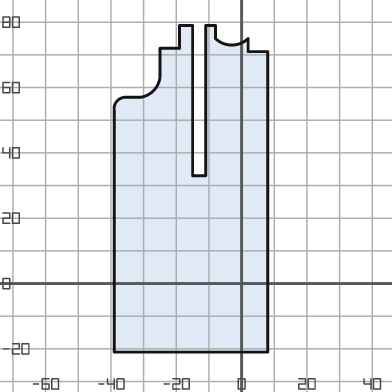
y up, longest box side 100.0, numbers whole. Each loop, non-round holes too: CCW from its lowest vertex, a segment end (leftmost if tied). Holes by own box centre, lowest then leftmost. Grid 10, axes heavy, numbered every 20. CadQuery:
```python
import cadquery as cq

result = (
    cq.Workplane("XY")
    .moveTo(-39.0, -21.0)
    .lineTo(8.0, -21.0)
    .lineTo(8.0, 71.0)
    .lineTo(2.0, 71.0)
    .lineTo(2.0, 75.0)
    .threePointArc((-3.0, 73.0), (-8.0, 75.0))
    .lineTo(-8.0, 79.0)
    .lineTo(-11.0, 79.0)
    .lineTo(-11.0, 33.0)
    .lineTo(-15.0, 33.0)
    .lineTo(-15.0, 79.0)
    .lineTo(-19.0, 79.0)
    .lineTo(-19.0, 72.0)
    .lineTo(-25.0, 72.0)
    .lineTo(-25.0, 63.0)
    .threePointArc((-27.0, 59.0), (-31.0, 57.0))
    .lineTo(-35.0, 57.0)
    .threePointArc((-38.0, 56.0), (-39.0, 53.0))
    .close()
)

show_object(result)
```